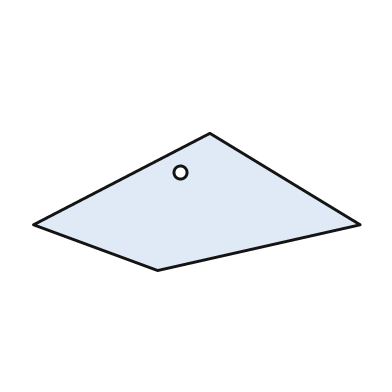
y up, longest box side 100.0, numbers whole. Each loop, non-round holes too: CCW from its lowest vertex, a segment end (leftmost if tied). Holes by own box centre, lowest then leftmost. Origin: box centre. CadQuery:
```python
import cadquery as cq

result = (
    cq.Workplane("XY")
    .moveTo(-12.0, -21.0)
    .lineTo(50.0, -7.0)
    .lineTo(4.0, 21.0)
    .lineTo(-50.0, -7.0)
    .close()
    .moveTo(-5.0, 9.0)
    .circle(2.0)
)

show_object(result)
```